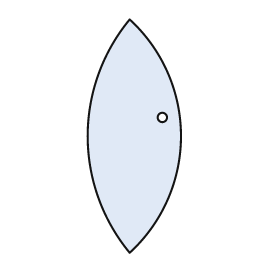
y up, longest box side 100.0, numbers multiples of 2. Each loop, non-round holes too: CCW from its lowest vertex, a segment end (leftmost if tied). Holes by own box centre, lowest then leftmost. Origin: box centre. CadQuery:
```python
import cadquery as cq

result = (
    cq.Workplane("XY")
    .moveTo(-2.0, -50.0)
    .threePointArc((20.0, 0.0), (-2.0, 50.0))
    .threePointArc((-20.0, 0.0), (-2.0, -50.0))
    .close()
    .moveTo(12.0, 8.0)
    .circle(2.0)
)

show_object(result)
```